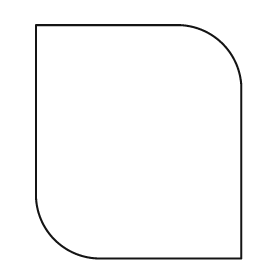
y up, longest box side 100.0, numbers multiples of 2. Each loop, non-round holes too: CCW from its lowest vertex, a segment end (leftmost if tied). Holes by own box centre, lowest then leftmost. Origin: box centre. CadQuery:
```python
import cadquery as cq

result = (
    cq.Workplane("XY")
    .moveTo(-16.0, -50.0)
    .lineTo(44.0, -50.0)
    .lineTo(44.0, 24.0)
    .threePointArc((36.0, 42.0), (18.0, 50.0))
    .lineTo(-44.0, 50.0)
    .lineTo(-44.0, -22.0)
    .threePointArc((-36.0, -42.0), (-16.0, -50.0))
    .close()
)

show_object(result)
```